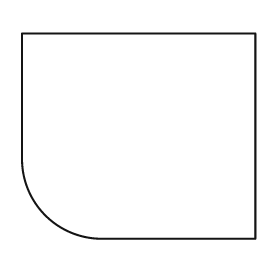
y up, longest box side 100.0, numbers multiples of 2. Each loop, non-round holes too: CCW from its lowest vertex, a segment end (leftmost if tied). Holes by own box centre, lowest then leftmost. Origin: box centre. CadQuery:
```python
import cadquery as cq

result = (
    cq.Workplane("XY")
    .moveTo(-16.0, -44.0)
    .lineTo(50.0, -44.0)
    .lineTo(50.0, 44.0)
    .lineTo(-50.0, 44.0)
    .lineTo(-50.0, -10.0)
    .threePointArc((-40.0, -34.0), (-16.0, -44.0))
    .close()
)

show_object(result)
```